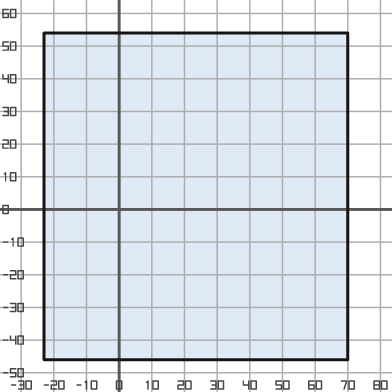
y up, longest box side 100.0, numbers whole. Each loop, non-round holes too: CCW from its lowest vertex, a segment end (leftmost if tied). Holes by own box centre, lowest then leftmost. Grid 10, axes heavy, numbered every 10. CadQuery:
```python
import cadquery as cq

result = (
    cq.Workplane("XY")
    .moveTo(-23.0, -46.0)
    .lineTo(70.0, -46.0)
    .lineTo(70.0, 54.0)
    .lineTo(-23.0, 54.0)
    .close()
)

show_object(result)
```